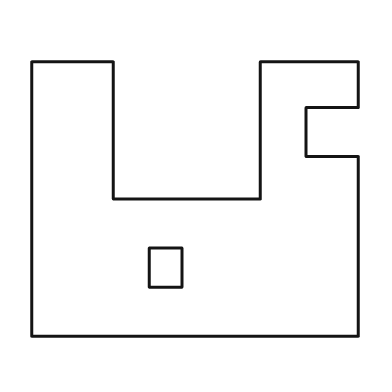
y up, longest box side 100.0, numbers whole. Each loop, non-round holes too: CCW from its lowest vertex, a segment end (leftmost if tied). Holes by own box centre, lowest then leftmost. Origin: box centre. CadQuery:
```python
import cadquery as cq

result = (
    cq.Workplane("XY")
    .moveTo(-50.0, -42.0)
    .lineTo(50.0, -42.0)
    .lineTo(50.0, 13.0)
    .lineTo(34.0, 13.0)
    .lineTo(34.0, 28.0)
    .lineTo(50.0, 28.0)
    .lineTo(50.0, 42.0)
    .lineTo(20.0, 42.0)
    .lineTo(20.0, 0.0)
    .lineTo(-25.0, 0.0)
    .lineTo(-25.0, 42.0)
    .lineTo(-50.0, 42.0)
    .close()
    .moveTo(-14.0, -27.0)
    .lineTo(-4.0, -27.0)
    .lineTo(-4.0, -15.0)
    .lineTo(-14.0, -15.0)
    .close()
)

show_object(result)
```